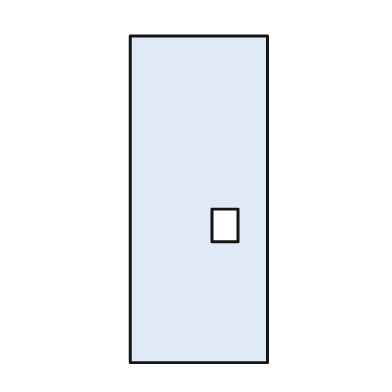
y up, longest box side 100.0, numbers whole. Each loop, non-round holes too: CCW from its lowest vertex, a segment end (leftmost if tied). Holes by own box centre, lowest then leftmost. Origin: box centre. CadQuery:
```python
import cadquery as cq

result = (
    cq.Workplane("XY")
    .moveTo(-21.0, -50.0)
    .lineTo(21.0, -50.0)
    .lineTo(21.0, 50.0)
    .lineTo(-21.0, 50.0)
    .close()
    .moveTo(4.0, -13.0)
    .lineTo(12.0, -13.0)
    .lineTo(12.0, -3.0)
    .lineTo(4.0, -3.0)
    .close()
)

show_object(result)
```